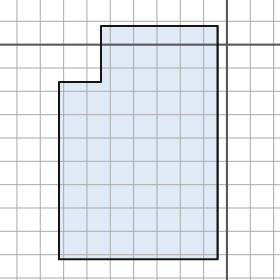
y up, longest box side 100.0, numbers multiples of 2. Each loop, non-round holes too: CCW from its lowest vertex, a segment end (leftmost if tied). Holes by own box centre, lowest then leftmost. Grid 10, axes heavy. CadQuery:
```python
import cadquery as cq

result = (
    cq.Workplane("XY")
    .moveTo(-72.0, -92.0)
    .lineTo(-4.0, -92.0)
    .lineTo(-4.0, 8.0)
    .lineTo(-54.0, 8.0)
    .lineTo(-54.0, -16.0)
    .lineTo(-72.0, -16.0)
    .close()
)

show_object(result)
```